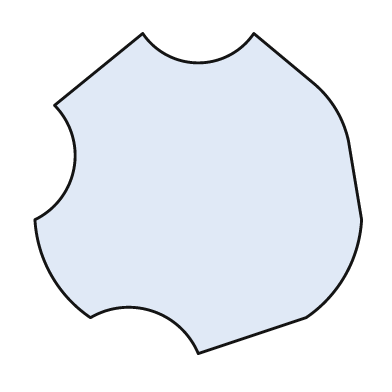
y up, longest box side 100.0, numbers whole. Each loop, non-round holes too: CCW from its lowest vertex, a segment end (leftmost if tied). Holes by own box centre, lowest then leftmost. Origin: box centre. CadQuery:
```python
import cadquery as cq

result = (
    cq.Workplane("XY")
    .moveTo(0.0, -49.0)
    .lineTo(33.0, -38.0)
    .threePointArc((45.0, -25.0), (50.0, -8.0))
    .lineTo(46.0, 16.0)
    .threePointArc((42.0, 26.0), (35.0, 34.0))
    .lineTo(17.0, 49.0)
    .threePointArc((0.0, 40.0), (-17.0, 49.0))
    .lineTo(-44.0, 27.0)
    .threePointArc((-38.0, 8.0), (-50.0, -8.0))
    .threePointArc((-45.0, -25.0), (-33.0, -38.0))
    .threePointArc((-14.0, -36.0), (0.0, -49.0))
    .close()
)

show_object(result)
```